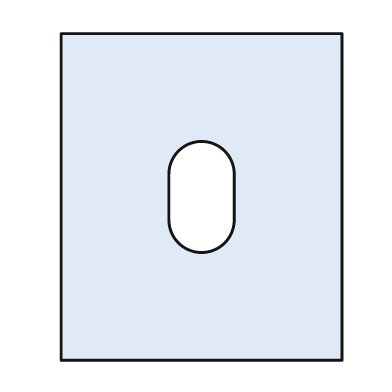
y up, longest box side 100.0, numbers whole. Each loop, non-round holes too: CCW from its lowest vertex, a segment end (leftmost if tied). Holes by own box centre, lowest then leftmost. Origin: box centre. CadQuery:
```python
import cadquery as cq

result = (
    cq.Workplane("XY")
    .moveTo(-43.0, -50.0)
    .lineTo(43.0, -50.0)
    .lineTo(43.0, 50.0)
    .lineTo(-43.0, 50.0)
    .close()
    .moveTo(-10.0, -7.0)
    .threePointArc((0.0, -17.0), (10.0, -7.0))
    .lineTo(10.0, 7.0)
    .threePointArc((0.0, 17.0), (-10.0, 7.0))
    .close()
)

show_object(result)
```